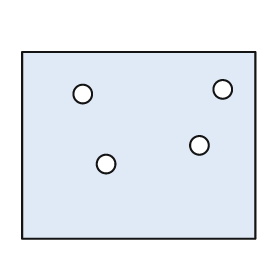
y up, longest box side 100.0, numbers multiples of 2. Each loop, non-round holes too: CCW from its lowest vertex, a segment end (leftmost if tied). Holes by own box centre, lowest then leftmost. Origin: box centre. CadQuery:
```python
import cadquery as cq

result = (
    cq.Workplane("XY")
    .moveTo(-50.0, -40.0)
    .lineTo(50.0, -40.0)
    .lineTo(50.0, 40.0)
    .lineTo(-50.0, 40.0)
    .close()
    .moveTo(-14.0, -8.0)
    .circle(4.0)
    .moveTo(26.0, 0.0)
    .circle(4.0)
    .moveTo(-24.0, 22.0)
    .circle(4.0)
    .moveTo(36.0, 24.0)
    .circle(4.0)
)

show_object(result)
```